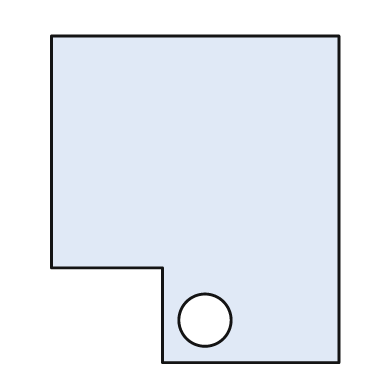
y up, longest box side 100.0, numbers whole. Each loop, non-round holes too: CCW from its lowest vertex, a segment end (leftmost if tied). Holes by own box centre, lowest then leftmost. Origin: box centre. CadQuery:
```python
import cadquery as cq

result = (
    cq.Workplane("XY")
    .moveTo(-10.0, -50.0)
    .lineTo(44.0, -50.0)
    .lineTo(44.0, 50.0)
    .lineTo(-44.0, 50.0)
    .lineTo(-44.0, -21.0)
    .lineTo(-10.0, -21.0)
    .close()
    .moveTo(3.0, -37.0)
    .circle(8.0)
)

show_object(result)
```